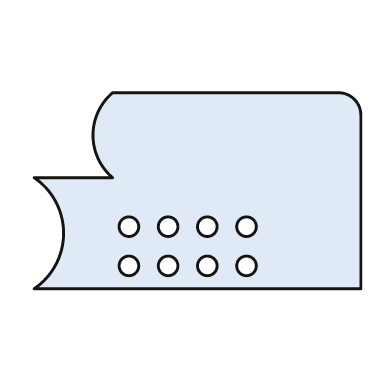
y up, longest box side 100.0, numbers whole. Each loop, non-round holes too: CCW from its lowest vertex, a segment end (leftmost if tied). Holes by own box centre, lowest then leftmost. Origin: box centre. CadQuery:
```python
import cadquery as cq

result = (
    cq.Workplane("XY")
    .moveTo(-50.0, -30.0)
    .lineTo(50.0, -30.0)
    .lineTo(50.0, 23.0)
    .threePointArc((48.0, 28.0), (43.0, 30.0))
    .lineTo(-26.0, 30.0)
    .threePointArc((-32.0, 17.0), (-26.0, 4.0))
    .lineTo(-50.0, 4.0)
    .threePointArc((-41.0, -13.0), (-50.0, -30.0))
    .close()
    .moveTo(-21.0, -23.0)
    .circle(3.0)
    .moveTo(-9.0, -23.0)
    .circle(3.0)
    .moveTo(3.0, -23.0)
    .circle(3.0)
    .moveTo(15.0, -23.0)
    .circle(3.0)
    .moveTo(-21.0, -11.0)
    .circle(3.0)
    .moveTo(-9.0, -11.0)
    .circle(3.0)
    .moveTo(3.0, -11.0)
    .circle(3.0)
    .moveTo(15.0, -11.0)
    .circle(3.0)
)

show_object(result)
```